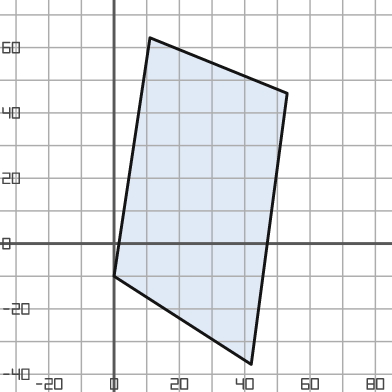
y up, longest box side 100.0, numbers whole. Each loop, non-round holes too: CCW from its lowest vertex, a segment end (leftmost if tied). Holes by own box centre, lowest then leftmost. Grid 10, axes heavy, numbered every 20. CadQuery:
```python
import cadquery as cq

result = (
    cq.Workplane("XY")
    .moveTo(42.0, -37.0)
    .lineTo(53.0, 46.0)
    .lineTo(11.0, 63.0)
    .lineTo(0.0, -10.0)
    .close()
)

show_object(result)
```